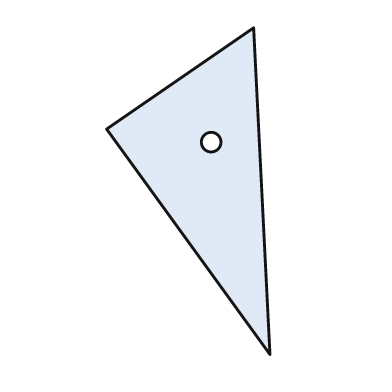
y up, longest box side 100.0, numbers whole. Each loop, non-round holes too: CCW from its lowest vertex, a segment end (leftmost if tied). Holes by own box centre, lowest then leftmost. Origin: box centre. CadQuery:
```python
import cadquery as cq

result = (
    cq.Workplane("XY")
    .moveTo(25.0, -50.0)
    .lineTo(20.0, 50.0)
    .lineTo(-25.0, 19.0)
    .close()
    .moveTo(7.0, 15.0)
    .circle(3.0)
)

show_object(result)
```